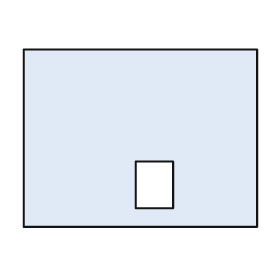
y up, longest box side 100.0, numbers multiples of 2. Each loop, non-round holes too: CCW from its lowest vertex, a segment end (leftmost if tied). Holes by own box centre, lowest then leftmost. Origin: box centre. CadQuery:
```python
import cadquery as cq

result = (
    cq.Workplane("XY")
    .moveTo(-50.0, -38.0)
    .lineTo(50.0, -38.0)
    .lineTo(50.0, 38.0)
    .lineTo(-50.0, 38.0)
    .close()
    .moveTo(-2.0, -30.0)
    .lineTo(14.0, -30.0)
    .lineTo(14.0, -10.0)
    .lineTo(-2.0, -10.0)
    .close()
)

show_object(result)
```